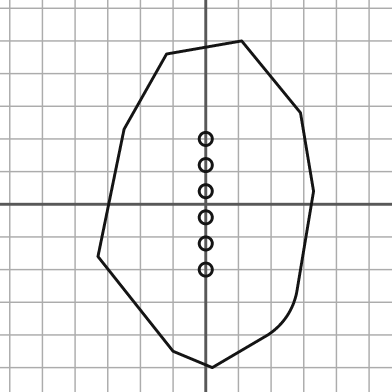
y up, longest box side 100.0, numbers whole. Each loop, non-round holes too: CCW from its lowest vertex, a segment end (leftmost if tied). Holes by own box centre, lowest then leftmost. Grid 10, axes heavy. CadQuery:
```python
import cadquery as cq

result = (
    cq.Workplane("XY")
    .moveTo(2.0, -50.0)
    .lineTo(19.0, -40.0)
    .threePointArc((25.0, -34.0), (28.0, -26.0))
    .lineTo(33.0, 4.0)
    .lineTo(29.0, 28.0)
    .lineTo(11.0, 50.0)
    .lineTo(-12.0, 46.0)
    .lineTo(-25.0, 23.0)
    .lineTo(-33.0, -16.0)
    .lineTo(-10.0, -45.0)
    .close()
    .moveTo(0.0, -20.0)
    .circle(2.0)
    .moveTo(0.0, -12.0)
    .circle(2.0)
    .moveTo(0.0, -4.0)
    .circle(2.0)
    .moveTo(0.0, 4.0)
    .circle(2.0)
    .moveTo(0.0, 12.0)
    .circle(2.0)
    .moveTo(0.0, 20.0)
    .circle(2.0)
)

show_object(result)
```